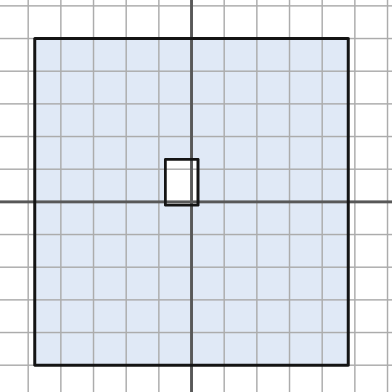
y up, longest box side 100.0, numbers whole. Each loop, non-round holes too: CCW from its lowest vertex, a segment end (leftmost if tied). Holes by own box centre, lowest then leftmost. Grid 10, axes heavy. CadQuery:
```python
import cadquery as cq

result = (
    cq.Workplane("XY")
    .moveTo(-48.0, -50.0)
    .lineTo(48.0, -50.0)
    .lineTo(48.0, 50.0)
    .lineTo(-48.0, 50.0)
    .close()
    .moveTo(-8.0, -1.0)
    .lineTo(2.0, -1.0)
    .lineTo(2.0, 13.0)
    .lineTo(-8.0, 13.0)
    .close()
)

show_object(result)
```